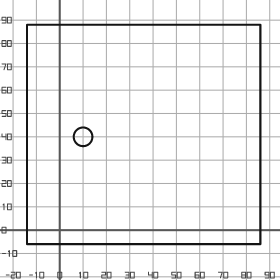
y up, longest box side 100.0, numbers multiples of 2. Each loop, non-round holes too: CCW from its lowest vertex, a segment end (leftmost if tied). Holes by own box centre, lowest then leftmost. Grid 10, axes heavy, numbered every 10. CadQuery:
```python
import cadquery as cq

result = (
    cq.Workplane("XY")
    .moveTo(-14.0, -6.0)
    .lineTo(86.0, -6.0)
    .lineTo(86.0, 88.0)
    .lineTo(-14.0, 88.0)
    .close()
    .moveTo(10.0, 40.0)
    .circle(4.0)
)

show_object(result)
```